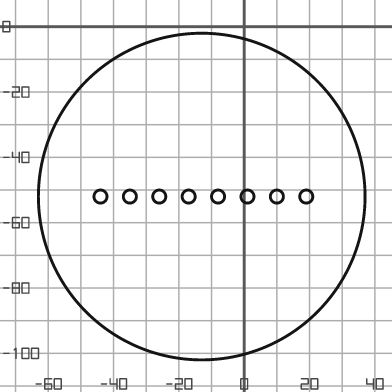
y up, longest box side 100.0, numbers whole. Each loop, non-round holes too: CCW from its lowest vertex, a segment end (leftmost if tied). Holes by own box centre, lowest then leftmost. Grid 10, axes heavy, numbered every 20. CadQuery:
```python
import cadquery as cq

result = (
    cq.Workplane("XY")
    .moveTo(-13.0, -52.0)
    .circle(50.0)
    .moveTo(-44.0, -52.0)
    .circle(2.0)
    .moveTo(-35.0, -52.0)
    .circle(2.0)
    .moveTo(-26.0, -52.0)
    .circle(2.0)
    .moveTo(-17.0, -52.0)
    .circle(2.0)
    .moveTo(-8.0, -52.0)
    .circle(2.0)
    .moveTo(1.0, -52.0)
    .circle(2.0)
    .moveTo(10.0, -52.0)
    .circle(2.0)
    .moveTo(19.0, -52.0)
    .circle(2.0)
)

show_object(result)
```